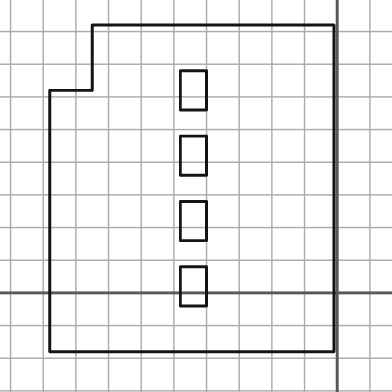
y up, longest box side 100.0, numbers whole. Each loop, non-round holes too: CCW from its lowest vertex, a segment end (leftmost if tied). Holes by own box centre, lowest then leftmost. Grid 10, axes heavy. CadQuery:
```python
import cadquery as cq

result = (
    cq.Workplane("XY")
    .moveTo(-88.0, -18.0)
    .lineTo(-1.0, -18.0)
    .lineTo(-1.0, 82.0)
    .lineTo(-75.0, 82.0)
    .lineTo(-75.0, 62.0)
    .lineTo(-88.0, 62.0)
    .close()
    .moveTo(-48.0, -4.0)
    .lineTo(-40.0, -4.0)
    .lineTo(-40.0, 8.0)
    .lineTo(-48.0, 8.0)
    .close()
    .moveTo(-48.0, 16.0)
    .lineTo(-40.0, 16.0)
    .lineTo(-40.0, 28.0)
    .lineTo(-48.0, 28.0)
    .close()
    .moveTo(-48.0, 36.0)
    .lineTo(-40.0, 36.0)
    .lineTo(-40.0, 48.0)
    .lineTo(-48.0, 48.0)
    .close()
    .moveTo(-48.0, 56.0)
    .lineTo(-40.0, 56.0)
    .lineTo(-40.0, 68.0)
    .lineTo(-48.0, 68.0)
    .close()
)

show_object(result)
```